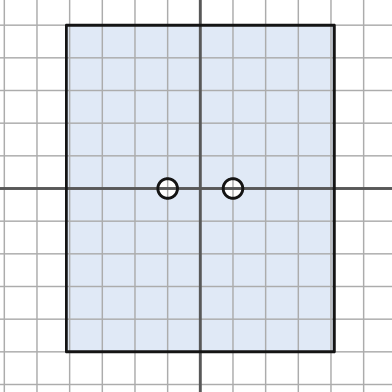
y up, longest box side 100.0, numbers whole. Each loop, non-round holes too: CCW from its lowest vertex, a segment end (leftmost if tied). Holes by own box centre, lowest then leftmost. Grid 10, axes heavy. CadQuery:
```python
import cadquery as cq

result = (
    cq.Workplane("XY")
    .moveTo(-41.0, -50.0)
    .lineTo(41.0, -50.0)
    .lineTo(41.0, 50.0)
    .lineTo(-41.0, 50.0)
    .close()
    .moveTo(-10.0, 0.0)
    .circle(3.0)
    .moveTo(10.0, 0.0)
    .circle(3.0)
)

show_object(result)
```